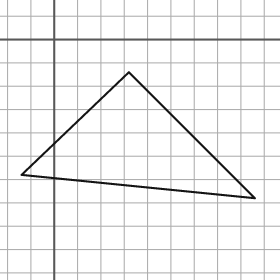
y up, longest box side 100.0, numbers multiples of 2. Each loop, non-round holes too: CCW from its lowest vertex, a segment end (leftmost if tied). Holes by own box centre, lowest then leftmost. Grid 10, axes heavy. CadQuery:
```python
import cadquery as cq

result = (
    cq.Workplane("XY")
    .moveTo(86.0, -68.0)
    .lineTo(32.0, -14.0)
    .lineTo(-14.0, -58.0)
    .close()
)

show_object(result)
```